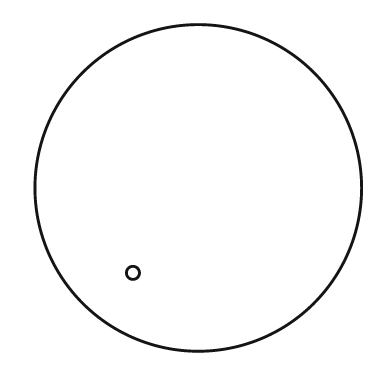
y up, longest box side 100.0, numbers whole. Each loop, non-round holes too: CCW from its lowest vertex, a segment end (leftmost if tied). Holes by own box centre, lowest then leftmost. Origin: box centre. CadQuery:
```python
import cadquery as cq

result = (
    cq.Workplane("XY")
    .moveTo(0.0, 0.0)
    .circle(50.0)
    .moveTo(-20.0, -26.0)
    .circle(2.0)
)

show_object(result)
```